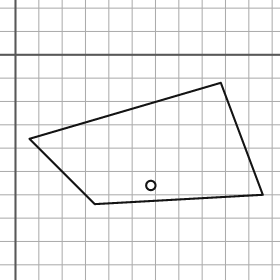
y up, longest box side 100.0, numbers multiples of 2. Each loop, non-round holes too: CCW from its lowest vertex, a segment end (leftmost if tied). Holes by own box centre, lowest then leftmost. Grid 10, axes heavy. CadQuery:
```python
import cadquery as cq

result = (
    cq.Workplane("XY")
    .moveTo(34.0, -64.0)
    .lineTo(106.0, -60.0)
    .lineTo(88.0, -12.0)
    .lineTo(6.0, -36.0)
    .close()
    .moveTo(58.0, -56.0)
    .circle(2.0)
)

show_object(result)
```